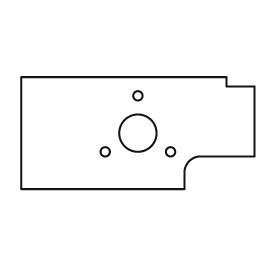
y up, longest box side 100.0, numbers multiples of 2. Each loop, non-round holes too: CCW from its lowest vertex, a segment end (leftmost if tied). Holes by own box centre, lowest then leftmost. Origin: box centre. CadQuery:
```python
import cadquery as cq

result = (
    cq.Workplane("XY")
    .moveTo(-50.0, -24.0)
    .lineTo(20.0, -24.0)
    .lineTo(20.0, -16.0)
    .threePointArc((22.0, -12.0), (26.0, -10.0))
    .lineTo(50.0, -10.0)
    .lineTo(50.0, 20.0)
    .lineTo(38.0, 20.0)
    .lineTo(38.0, 24.0)
    .lineTo(-50.0, 24.0)
    .close()
    .moveTo(-14.0, -8.0)
    .circle(2.0)
    .moveTo(14.0, -8.0)
    .circle(2.0)
    .moveTo(0.0, 0.0)
    .circle(8.0)
    .moveTo(0.0, 16.0)
    .circle(2.0)
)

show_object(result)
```